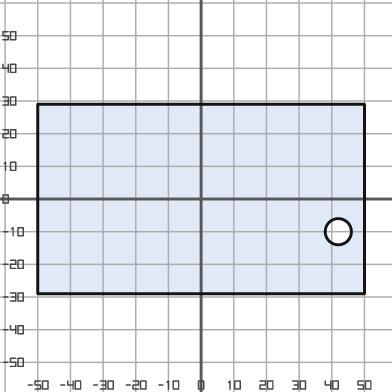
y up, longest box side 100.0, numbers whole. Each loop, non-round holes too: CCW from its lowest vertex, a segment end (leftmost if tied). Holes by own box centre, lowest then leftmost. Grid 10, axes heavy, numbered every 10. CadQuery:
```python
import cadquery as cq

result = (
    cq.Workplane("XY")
    .moveTo(-50.0, -29.0)
    .lineTo(50.0, -29.0)
    .lineTo(50.0, 29.0)
    .lineTo(-50.0, 29.0)
    .close()
    .moveTo(42.0, -10.0)
    .circle(4.0)
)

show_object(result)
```